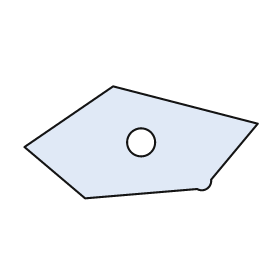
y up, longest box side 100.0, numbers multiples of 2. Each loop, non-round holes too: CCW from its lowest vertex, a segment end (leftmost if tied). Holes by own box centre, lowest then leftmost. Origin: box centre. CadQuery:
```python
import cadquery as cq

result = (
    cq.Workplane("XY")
    .moveTo(-24.0, -24.0)
    .lineTo(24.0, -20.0)
    .threePointArc((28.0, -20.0), (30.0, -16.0))
    .lineTo(50.0, 8.0)
    .lineTo(-12.0, 24.0)
    .lineTo(-50.0, -2.0)
    .close()
    .moveTo(0.0, 0.0)
    .circle(6.0)
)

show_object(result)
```